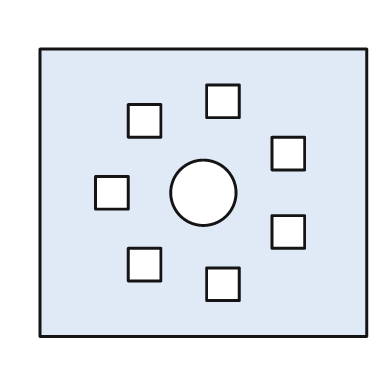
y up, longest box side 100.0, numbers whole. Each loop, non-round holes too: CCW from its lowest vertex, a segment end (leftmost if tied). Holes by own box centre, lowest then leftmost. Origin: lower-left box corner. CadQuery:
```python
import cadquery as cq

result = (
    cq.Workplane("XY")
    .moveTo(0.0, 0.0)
    .lineTo(100.0, 0.0)
    .lineTo(100.0, 88.0)
    .lineTo(0.0, 88.0)
    .close()
    .moveTo(51.0, 11.0)
    .lineTo(61.0, 11.0)
    .lineTo(61.0, 21.0)
    .lineTo(51.0, 21.0)
    .close()
    .moveTo(27.0, 17.0)
    .lineTo(37.0, 17.0)
    .lineTo(37.0, 27.0)
    .lineTo(27.0, 27.0)
    .close()
    .moveTo(71.0, 27.0)
    .lineTo(81.0, 27.0)
    .lineTo(81.0, 37.0)
    .lineTo(71.0, 37.0)
    .close()
    .moveTo(17.0, 39.0)
    .lineTo(27.0, 39.0)
    .lineTo(27.0, 49.0)
    .lineTo(17.0, 49.0)
    .close()
    .moveTo(50.0, 44.0)
    .circle(10.0)
    .moveTo(71.0, 51.0)
    .lineTo(81.0, 51.0)
    .lineTo(81.0, 61.0)
    .lineTo(71.0, 61.0)
    .close()
    .moveTo(27.0, 61.0)
    .lineTo(37.0, 61.0)
    .lineTo(37.0, 71.0)
    .lineTo(27.0, 71.0)
    .close()
    .moveTo(51.0, 67.0)
    .lineTo(61.0, 67.0)
    .lineTo(61.0, 77.0)
    .lineTo(51.0, 77.0)
    .close()
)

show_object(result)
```